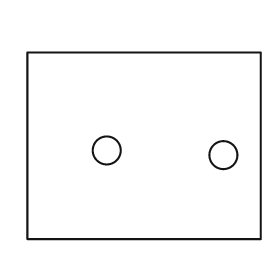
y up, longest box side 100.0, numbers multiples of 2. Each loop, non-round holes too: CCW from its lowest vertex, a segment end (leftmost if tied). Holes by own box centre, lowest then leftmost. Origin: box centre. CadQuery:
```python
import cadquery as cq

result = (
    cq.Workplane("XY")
    .moveTo(-50.0, -40.0)
    .lineTo(50.0, -40.0)
    .lineTo(50.0, 40.0)
    .lineTo(-50.0, 40.0)
    .close()
    .moveTo(34.0, -4.0)
    .circle(6.0)
    .moveTo(-16.0, -2.0)
    .circle(6.0)
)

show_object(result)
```